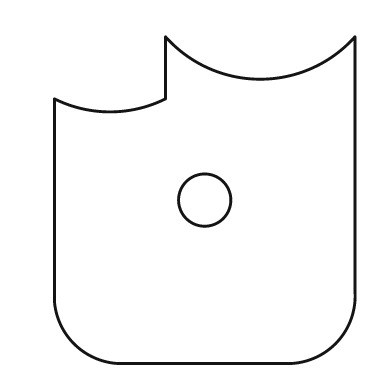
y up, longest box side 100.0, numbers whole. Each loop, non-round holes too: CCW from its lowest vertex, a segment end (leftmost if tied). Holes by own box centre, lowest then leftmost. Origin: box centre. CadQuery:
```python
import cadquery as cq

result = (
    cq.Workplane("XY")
    .moveTo(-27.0, -50.0)
    .lineTo(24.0, -50.0)
    .threePointArc((40.0, -44.0), (46.0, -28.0))
    .lineTo(46.0, 50.0)
    .threePointArc((17.0, 37.0), (-12.0, 50.0))
    .lineTo(-12.0, 31.0)
    .threePointArc((-29.0, 27.0), (-46.0, 31.0))
    .lineTo(-46.0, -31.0)
    .threePointArc((-40.0, -44.0), (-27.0, -50.0))
    .close()
    .moveTo(0.0, 0.0)
    .circle(8.0)
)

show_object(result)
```